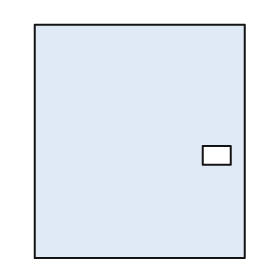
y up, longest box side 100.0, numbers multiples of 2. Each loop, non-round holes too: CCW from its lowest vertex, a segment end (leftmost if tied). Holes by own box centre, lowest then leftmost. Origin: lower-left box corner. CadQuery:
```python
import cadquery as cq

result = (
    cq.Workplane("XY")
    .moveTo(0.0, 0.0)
    .lineTo(90.0, 0.0)
    .lineTo(90.0, 100.0)
    .lineTo(0.0, 100.0)
    .close()
    .moveTo(72.0, 40.0)
    .lineTo(84.0, 40.0)
    .lineTo(84.0, 48.0)
    .lineTo(72.0, 48.0)
    .close()
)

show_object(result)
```